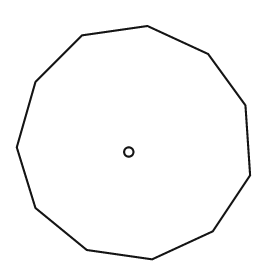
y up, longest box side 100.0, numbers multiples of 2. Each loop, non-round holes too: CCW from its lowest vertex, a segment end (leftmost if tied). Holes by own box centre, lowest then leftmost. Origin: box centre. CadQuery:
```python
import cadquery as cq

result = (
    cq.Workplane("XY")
    .moveTo(8.0, -50.0)
    .lineTo(34.0, -38.0)
    .lineTo(50.0, -14.0)
    .lineTo(48.0, 16.0)
    .lineTo(32.0, 38.0)
    .lineTo(6.0, 50.0)
    .lineTo(-22.0, 46.0)
    .lineTo(-42.0, 26.0)
    .lineTo(-50.0, -2.0)
    .lineTo(-42.0, -28.0)
    .lineTo(-20.0, -46.0)
    .close()
    .moveTo(-2.0, -4.0)
    .circle(2.0)
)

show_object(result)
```